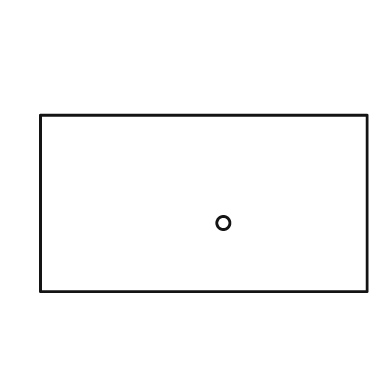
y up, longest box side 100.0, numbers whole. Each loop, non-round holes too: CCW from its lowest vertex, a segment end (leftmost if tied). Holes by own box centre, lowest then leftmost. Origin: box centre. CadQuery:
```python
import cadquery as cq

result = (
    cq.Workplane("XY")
    .moveTo(-50.0, -27.0)
    .lineTo(50.0, -27.0)
    .lineTo(50.0, 27.0)
    .lineTo(-50.0, 27.0)
    .close()
    .moveTo(6.0, -6.0)
    .circle(2.0)
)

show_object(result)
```